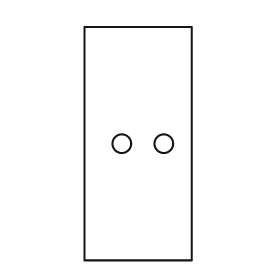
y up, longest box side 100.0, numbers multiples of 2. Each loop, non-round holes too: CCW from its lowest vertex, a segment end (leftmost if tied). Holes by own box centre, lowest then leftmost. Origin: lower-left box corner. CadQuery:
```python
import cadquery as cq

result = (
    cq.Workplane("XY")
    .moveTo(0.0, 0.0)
    .lineTo(46.0, 0.0)
    .lineTo(46.0, 100.0)
    .lineTo(0.0, 100.0)
    .close()
    .moveTo(16.0, 50.0)
    .circle(4.0)
    .moveTo(34.0, 50.0)
    .circle(4.0)
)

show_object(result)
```